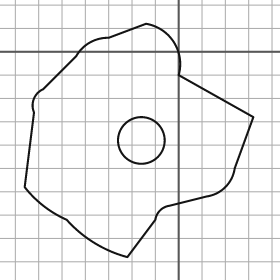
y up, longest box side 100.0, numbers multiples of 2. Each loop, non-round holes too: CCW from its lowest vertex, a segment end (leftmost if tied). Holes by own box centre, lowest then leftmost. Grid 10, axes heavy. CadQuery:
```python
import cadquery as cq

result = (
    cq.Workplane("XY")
    .moveTo(-22.0, -88.0)
    .lineTo(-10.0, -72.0)
    .threePointArc((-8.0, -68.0), (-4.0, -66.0))
    .lineTo(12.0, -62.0)
    .threePointArc((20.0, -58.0), (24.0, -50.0))
    .lineTo(32.0, -28.0)
    .lineTo(0.0, -10.0)
    .threePointArc((-2.0, 4.0), (-14.0, 12.0))
    .lineTo(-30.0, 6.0)
    .threePointArc((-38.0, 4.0), (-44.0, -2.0))
    .lineTo(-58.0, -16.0)
    .threePointArc((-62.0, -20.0), (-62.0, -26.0))
    .lineTo(-66.0, -58.0)
    .threePointArc((-58.0, -66.0), (-48.0, -72.0))
    .threePointArc((-36.0, -82.0), (-22.0, -88.0))
    .close()
    .moveTo(-16.0, -38.0)
    .circle(10.0)
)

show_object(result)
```